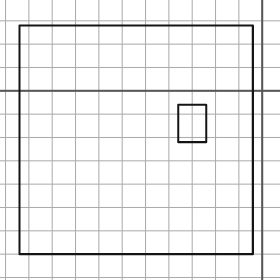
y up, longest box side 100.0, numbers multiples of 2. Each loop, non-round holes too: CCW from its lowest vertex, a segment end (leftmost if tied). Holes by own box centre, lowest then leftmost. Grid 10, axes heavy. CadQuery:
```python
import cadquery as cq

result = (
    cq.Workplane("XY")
    .moveTo(-104.0, -70.0)
    .lineTo(-4.0, -70.0)
    .lineTo(-4.0, 28.0)
    .lineTo(-104.0, 28.0)
    .close()
    .moveTo(-36.0, -22.0)
    .lineTo(-24.0, -22.0)
    .lineTo(-24.0, -6.0)
    .lineTo(-36.0, -6.0)
    .close()
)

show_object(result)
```